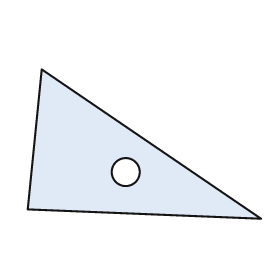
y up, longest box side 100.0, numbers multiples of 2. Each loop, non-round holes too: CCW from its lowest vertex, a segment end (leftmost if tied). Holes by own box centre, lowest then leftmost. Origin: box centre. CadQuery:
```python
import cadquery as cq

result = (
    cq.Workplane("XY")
    .moveTo(50.0, -32.0)
    .lineTo(-44.0, 32.0)
    .lineTo(-50.0, -28.0)
    .close()
    .moveTo(-8.0, -12.0)
    .circle(6.0)
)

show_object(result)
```